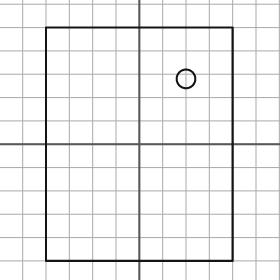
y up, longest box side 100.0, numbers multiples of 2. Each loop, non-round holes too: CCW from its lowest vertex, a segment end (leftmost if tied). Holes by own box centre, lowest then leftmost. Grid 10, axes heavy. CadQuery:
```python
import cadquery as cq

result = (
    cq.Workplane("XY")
    .moveTo(-40.0, -50.0)
    .lineTo(40.0, -50.0)
    .lineTo(40.0, 50.0)
    .lineTo(-40.0, 50.0)
    .close()
    .moveTo(20.0, 28.0)
    .circle(4.0)
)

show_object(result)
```